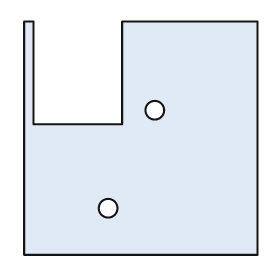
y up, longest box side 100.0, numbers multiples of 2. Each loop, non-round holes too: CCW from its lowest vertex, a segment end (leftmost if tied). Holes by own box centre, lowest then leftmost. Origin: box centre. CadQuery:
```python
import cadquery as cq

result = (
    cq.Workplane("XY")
    .moveTo(-50.0, -50.0)
    .lineTo(50.0, -50.0)
    .lineTo(50.0, 50.0)
    .lineTo(-8.0, 50.0)
    .lineTo(-8.0, 6.0)
    .lineTo(-46.0, 6.0)
    .lineTo(-46.0, 50.0)
    .lineTo(-50.0, 50.0)
    .close()
    .moveTo(-14.0, -30.0)
    .circle(4.0)
    .moveTo(6.0, 12.0)
    .circle(4.0)
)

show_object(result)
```